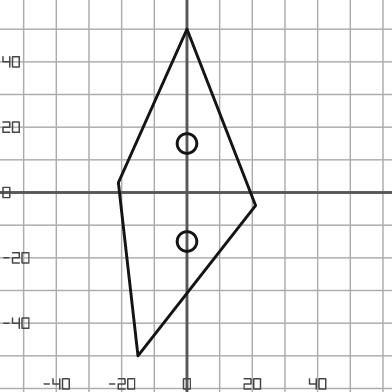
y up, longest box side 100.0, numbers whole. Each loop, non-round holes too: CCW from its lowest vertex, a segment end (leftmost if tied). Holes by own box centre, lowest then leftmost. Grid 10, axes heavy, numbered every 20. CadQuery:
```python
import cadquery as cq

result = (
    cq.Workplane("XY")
    .moveTo(-15.0, -50.0)
    .lineTo(21.0, -4.0)
    .lineTo(0.0, 50.0)
    .lineTo(-21.0, 3.0)
    .close()
    .moveTo(0.0, -15.0)
    .circle(3.0)
    .moveTo(0.0, 15.0)
    .circle(3.0)
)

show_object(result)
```